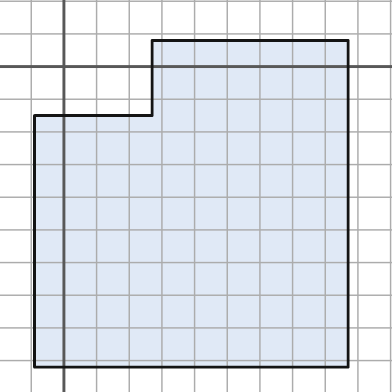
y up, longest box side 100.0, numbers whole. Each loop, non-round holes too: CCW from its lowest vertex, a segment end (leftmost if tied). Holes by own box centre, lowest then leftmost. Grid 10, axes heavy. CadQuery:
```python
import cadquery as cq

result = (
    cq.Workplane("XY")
    .moveTo(-9.0, -92.0)
    .lineTo(87.0, -92.0)
    .lineTo(87.0, 8.0)
    .lineTo(27.0, 8.0)
    .lineTo(27.0, -15.0)
    .lineTo(-9.0, -15.0)
    .close()
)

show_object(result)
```